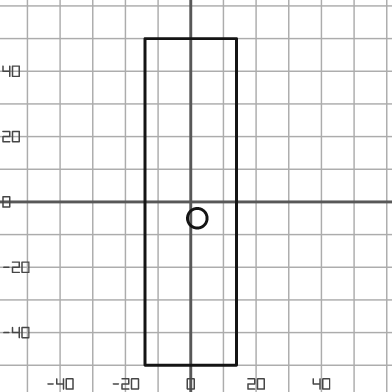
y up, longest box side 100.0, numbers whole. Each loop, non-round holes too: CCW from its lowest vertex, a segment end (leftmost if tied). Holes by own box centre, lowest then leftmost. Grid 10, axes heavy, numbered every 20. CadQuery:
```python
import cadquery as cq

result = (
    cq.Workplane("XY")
    .moveTo(-14.0, -50.0)
    .lineTo(14.0, -50.0)
    .lineTo(14.0, 50.0)
    .lineTo(-14.0, 50.0)
    .close()
    .moveTo(2.0, -5.0)
    .circle(3.0)
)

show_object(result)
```